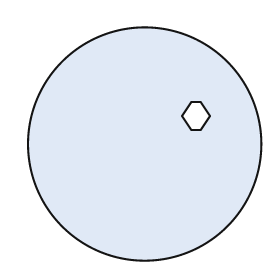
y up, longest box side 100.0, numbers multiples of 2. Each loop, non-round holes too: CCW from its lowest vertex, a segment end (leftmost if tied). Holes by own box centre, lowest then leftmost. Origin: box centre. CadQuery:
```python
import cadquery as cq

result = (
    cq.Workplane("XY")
    .moveTo(0.0, 0.0)
    .circle(50.0)
    .moveTo(20.0, 6.0)
    .lineTo(24.0, 6.0)
    .lineTo(28.0, 12.0)
    .lineTo(24.0, 18.0)
    .lineTo(20.0, 18.0)
    .lineTo(16.0, 12.0)
    .close()
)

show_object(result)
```